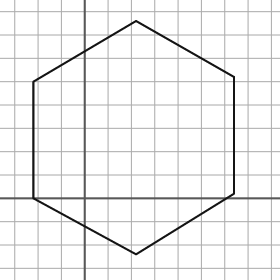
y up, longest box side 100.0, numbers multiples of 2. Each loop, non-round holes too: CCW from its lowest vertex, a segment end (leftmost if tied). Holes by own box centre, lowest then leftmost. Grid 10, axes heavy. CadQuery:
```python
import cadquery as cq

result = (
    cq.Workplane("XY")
    .moveTo(22.0, -24.0)
    .lineTo(64.0, 2.0)
    .lineTo(64.0, 52.0)
    .lineTo(22.0, 76.0)
    .lineTo(-22.0, 50.0)
    .lineTo(-22.0, 0.0)
    .close()
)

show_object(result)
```